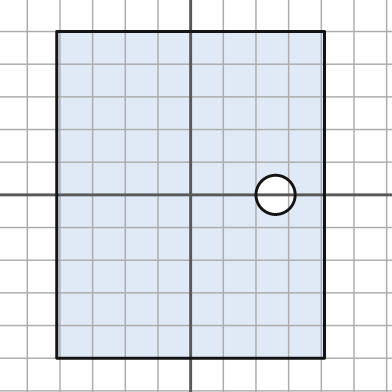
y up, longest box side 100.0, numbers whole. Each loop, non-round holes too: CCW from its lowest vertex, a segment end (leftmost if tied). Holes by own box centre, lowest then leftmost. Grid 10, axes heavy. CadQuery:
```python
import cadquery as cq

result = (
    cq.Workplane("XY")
    .moveTo(-41.0, -50.0)
    .lineTo(41.0, -50.0)
    .lineTo(41.0, 50.0)
    .lineTo(-41.0, 50.0)
    .close()
    .moveTo(26.0, 0.0)
    .circle(6.0)
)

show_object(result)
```